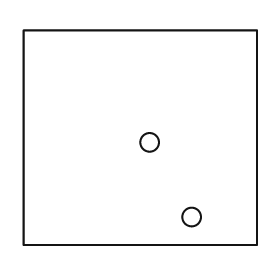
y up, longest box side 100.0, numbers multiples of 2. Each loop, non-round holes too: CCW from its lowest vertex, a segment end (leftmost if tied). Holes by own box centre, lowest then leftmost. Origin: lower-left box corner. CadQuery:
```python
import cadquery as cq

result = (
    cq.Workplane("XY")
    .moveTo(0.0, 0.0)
    .lineTo(100.0, 0.0)
    .lineTo(100.0, 92.0)
    .lineTo(0.0, 92.0)
    .close()
    .moveTo(72.0, 12.0)
    .circle(4.0)
    .moveTo(54.0, 44.0)
    .circle(4.0)
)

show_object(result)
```